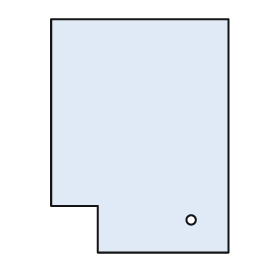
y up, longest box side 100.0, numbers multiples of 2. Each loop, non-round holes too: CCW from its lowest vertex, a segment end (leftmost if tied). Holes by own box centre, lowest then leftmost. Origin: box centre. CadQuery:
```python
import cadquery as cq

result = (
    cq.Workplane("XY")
    .moveTo(-18.0, -50.0)
    .lineTo(38.0, -50.0)
    .lineTo(38.0, 50.0)
    .lineTo(-38.0, 50.0)
    .lineTo(-38.0, -30.0)
    .lineTo(-18.0, -30.0)
    .close()
    .moveTo(22.0, -36.0)
    .circle(2.0)
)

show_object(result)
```